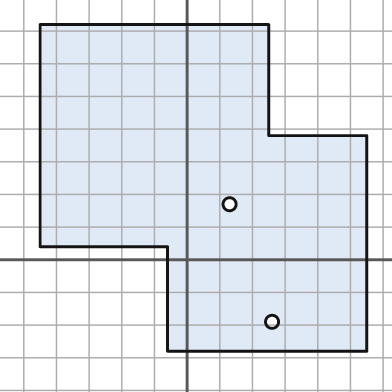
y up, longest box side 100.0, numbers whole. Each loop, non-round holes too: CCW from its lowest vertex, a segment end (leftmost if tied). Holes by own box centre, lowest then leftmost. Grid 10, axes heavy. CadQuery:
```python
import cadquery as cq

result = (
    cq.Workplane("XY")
    .moveTo(-6.0, -28.0)
    .lineTo(55.0, -28.0)
    .lineTo(55.0, 38.0)
    .lineTo(25.0, 38.0)
    .lineTo(25.0, 72.0)
    .lineTo(-45.0, 72.0)
    .lineTo(-45.0, 4.0)
    .lineTo(-6.0, 4.0)
    .close()
    .moveTo(26.0, -19.0)
    .circle(2.0)
    .moveTo(13.0, 17.0)
    .circle(2.0)
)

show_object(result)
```